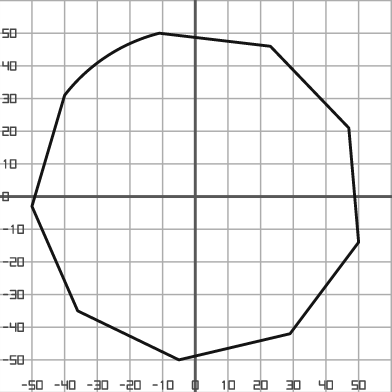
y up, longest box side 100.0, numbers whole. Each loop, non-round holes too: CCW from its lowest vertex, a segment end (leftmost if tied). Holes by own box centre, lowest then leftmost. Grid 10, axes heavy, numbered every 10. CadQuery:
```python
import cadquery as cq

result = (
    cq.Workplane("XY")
    .moveTo(-5.0, -50.0)
    .lineTo(29.0, -42.0)
    .lineTo(50.0, -14.0)
    .lineTo(47.0, 21.0)
    .lineTo(23.0, 46.0)
    .lineTo(-11.0, 50.0)
    .threePointArc((-27.0, 43.0), (-40.0, 31.0))
    .lineTo(-50.0, -3.0)
    .lineTo(-36.0, -35.0)
    .close()
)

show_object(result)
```